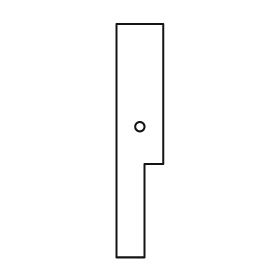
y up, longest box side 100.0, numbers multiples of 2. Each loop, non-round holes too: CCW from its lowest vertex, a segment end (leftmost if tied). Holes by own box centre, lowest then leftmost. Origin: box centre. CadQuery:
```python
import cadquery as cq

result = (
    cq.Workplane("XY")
    .moveTo(-10.0, -50.0)
    .lineTo(2.0, -50.0)
    .lineTo(2.0, -10.0)
    .lineTo(10.0, -10.0)
    .lineTo(10.0, 50.0)
    .lineTo(-10.0, 50.0)
    .close()
    .moveTo(0.0, 6.0)
    .circle(2.0)
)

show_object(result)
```